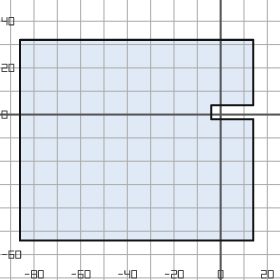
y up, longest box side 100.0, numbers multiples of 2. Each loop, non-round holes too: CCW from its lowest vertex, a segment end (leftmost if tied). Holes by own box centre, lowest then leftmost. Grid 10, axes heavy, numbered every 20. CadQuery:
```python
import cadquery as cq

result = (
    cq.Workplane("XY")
    .moveTo(-86.0, -54.0)
    .lineTo(14.0, -54.0)
    .lineTo(14.0, -2.0)
    .lineTo(-4.0, -2.0)
    .lineTo(-4.0, 4.0)
    .lineTo(14.0, 4.0)
    .lineTo(14.0, 32.0)
    .lineTo(-86.0, 32.0)
    .close()
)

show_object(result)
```